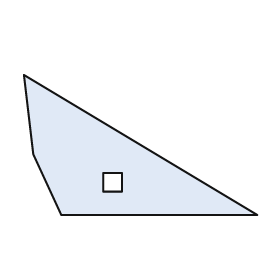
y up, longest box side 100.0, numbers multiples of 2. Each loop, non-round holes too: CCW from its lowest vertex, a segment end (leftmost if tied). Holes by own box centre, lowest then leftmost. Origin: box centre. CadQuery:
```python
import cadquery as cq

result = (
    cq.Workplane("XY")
    .moveTo(-34.0, -30.0)
    .lineTo(50.0, -30.0)
    .lineTo(-50.0, 30.0)
    .lineTo(-46.0, -4.0)
    .close()
    .moveTo(-16.0, -20.0)
    .lineTo(-8.0, -20.0)
    .lineTo(-8.0, -12.0)
    .lineTo(-16.0, -12.0)
    .close()
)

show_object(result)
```